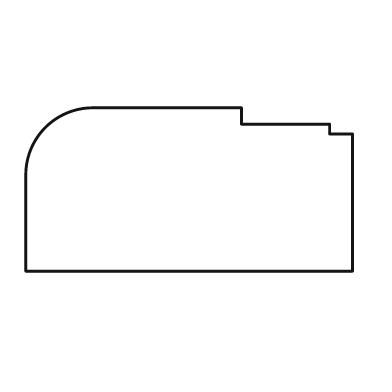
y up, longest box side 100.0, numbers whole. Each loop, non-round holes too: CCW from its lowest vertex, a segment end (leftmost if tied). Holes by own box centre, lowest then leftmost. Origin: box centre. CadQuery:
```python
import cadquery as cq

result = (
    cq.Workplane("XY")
    .moveTo(-50.0, -25.0)
    .lineTo(50.0, -25.0)
    .lineTo(50.0, 17.0)
    .lineTo(43.0, 17.0)
    .lineTo(43.0, 20.0)
    .lineTo(16.0, 20.0)
    .lineTo(16.0, 25.0)
    .lineTo(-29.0, 25.0)
    .threePointArc((-44.0, 19.0), (-50.0, 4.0))
    .close()
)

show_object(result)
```